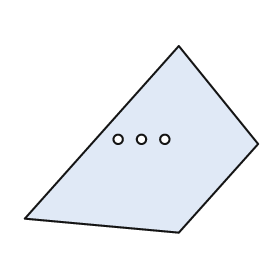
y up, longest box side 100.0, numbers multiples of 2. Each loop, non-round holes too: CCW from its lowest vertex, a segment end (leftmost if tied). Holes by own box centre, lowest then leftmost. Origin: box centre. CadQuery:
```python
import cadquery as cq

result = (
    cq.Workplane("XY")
    .moveTo(16.0, -40.0)
    .lineTo(50.0, -2.0)
    .lineTo(16.0, 40.0)
    .lineTo(-50.0, -34.0)
    .close()
    .moveTo(-10.0, 0.0)
    .circle(2.0)
    .moveTo(0.0, 0.0)
    .circle(2.0)
    .moveTo(10.0, 0.0)
    .circle(2.0)
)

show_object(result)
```